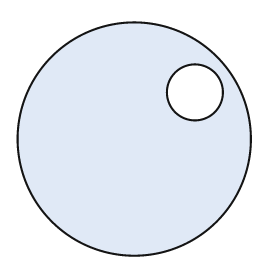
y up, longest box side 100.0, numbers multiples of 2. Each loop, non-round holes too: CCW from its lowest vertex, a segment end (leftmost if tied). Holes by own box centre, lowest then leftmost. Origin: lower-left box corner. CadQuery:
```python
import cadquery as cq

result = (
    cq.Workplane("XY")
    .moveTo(50.0, 50.0)
    .circle(50.0)
    .moveTo(76.0, 70.0)
    .circle(12.0)
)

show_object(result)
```